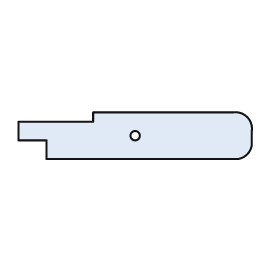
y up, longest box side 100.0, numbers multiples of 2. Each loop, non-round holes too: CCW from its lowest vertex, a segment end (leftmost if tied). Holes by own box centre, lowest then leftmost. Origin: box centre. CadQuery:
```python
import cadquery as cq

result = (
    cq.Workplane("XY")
    .moveTo(-38.0, -10.0)
    .lineTo(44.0, -10.0)
    .threePointArc((48.0, -8.0), (50.0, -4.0))
    .lineTo(50.0, 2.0)
    .threePointArc((48.0, 8.0), (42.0, 10.0))
    .lineTo(-18.0, 10.0)
    .lineTo(-18.0, 6.0)
    .lineTo(-50.0, 6.0)
    .lineTo(-50.0, -2.0)
    .lineTo(-38.0, -2.0)
    .close()
    .moveTo(0.0, 0.0)
    .circle(2.0)
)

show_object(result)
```